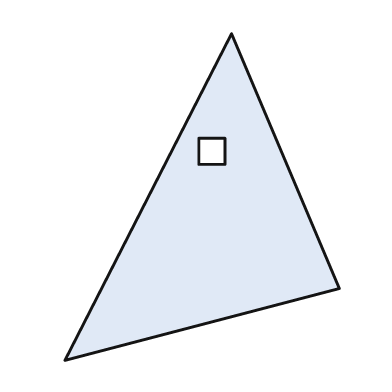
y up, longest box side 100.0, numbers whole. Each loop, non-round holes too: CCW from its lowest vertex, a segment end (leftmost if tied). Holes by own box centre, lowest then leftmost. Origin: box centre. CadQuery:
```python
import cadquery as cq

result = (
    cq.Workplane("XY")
    .moveTo(-42.0, -50.0)
    .lineTo(42.0, -28.0)
    .lineTo(9.0, 50.0)
    .close()
    .moveTo(-1.0, 10.0)
    .lineTo(7.0, 10.0)
    .lineTo(7.0, 18.0)
    .lineTo(-1.0, 18.0)
    .close()
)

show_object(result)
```